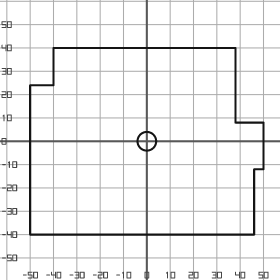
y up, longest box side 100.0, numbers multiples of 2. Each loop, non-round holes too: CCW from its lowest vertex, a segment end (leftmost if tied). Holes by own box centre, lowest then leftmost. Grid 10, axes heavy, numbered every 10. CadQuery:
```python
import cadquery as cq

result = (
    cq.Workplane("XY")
    .moveTo(-50.0, -40.0)
    .lineTo(46.0, -40.0)
    .lineTo(46.0, -12.0)
    .lineTo(50.0, -12.0)
    .lineTo(50.0, 8.0)
    .lineTo(38.0, 8.0)
    .lineTo(38.0, 40.0)
    .lineTo(-40.0, 40.0)
    .lineTo(-40.0, 24.0)
    .lineTo(-50.0, 24.0)
    .close()
    .moveTo(0.0, 0.0)
    .circle(4.0)
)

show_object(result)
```